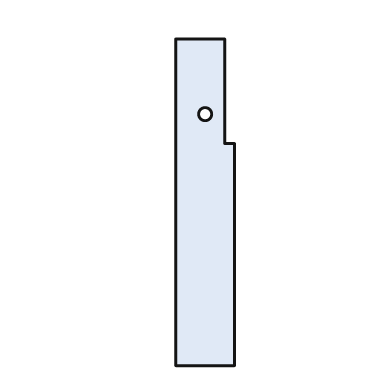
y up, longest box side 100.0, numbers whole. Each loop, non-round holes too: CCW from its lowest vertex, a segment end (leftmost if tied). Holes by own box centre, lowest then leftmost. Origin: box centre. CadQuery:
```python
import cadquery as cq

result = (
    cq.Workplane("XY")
    .moveTo(-9.0, -50.0)
    .lineTo(9.0, -50.0)
    .lineTo(9.0, 18.0)
    .lineTo(6.0, 18.0)
    .lineTo(6.0, 50.0)
    .lineTo(-9.0, 50.0)
    .close()
    .moveTo(0.0, 27.0)
    .circle(2.0)
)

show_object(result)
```